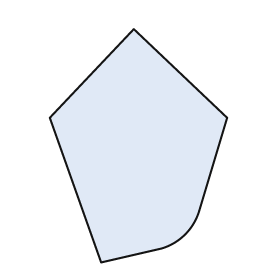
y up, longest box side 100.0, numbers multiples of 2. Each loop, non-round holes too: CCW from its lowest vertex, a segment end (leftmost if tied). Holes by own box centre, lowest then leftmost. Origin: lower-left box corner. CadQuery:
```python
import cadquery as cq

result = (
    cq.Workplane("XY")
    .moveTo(22.0, 0.0)
    .lineTo(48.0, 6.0)
    .threePointArc((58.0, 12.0), (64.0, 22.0))
    .lineTo(76.0, 62.0)
    .lineTo(36.0, 100.0)
    .lineTo(0.0, 62.0)
    .close()
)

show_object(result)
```